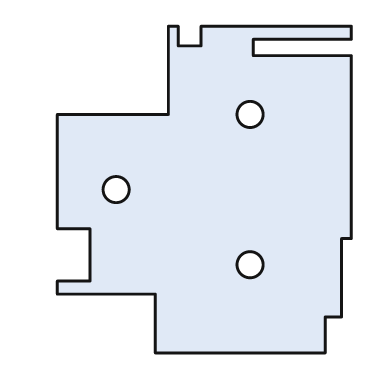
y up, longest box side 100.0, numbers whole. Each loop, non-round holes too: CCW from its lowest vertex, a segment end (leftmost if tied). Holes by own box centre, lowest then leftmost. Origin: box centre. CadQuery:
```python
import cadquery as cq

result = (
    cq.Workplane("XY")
    .moveTo(-15.0, -50.0)
    .lineTo(37.0, -50.0)
    .lineTo(37.0, -39.0)
    .lineTo(42.0, -39.0)
    .lineTo(42.0, -15.0)
    .lineTo(45.0, -15.0)
    .lineTo(45.0, 41.0)
    .lineTo(15.0, 41.0)
    .lineTo(15.0, 46.0)
    .lineTo(45.0, 46.0)
    .lineTo(45.0, 50.0)
    .lineTo(-1.0, 50.0)
    .lineTo(-1.0, 44.0)
    .lineTo(-8.0, 44.0)
    .lineTo(-8.0, 50.0)
    .lineTo(-11.0, 50.0)
    .lineTo(-11.0, 23.0)
    .lineTo(-45.0, 23.0)
    .lineTo(-45.0, -12.0)
    .lineTo(-35.0, -12.0)
    .lineTo(-35.0, -28.0)
    .lineTo(-45.0, -28.0)
    .lineTo(-45.0, -32.0)
    .lineTo(-15.0, -32.0)
    .close()
    .moveTo(14.0, -23.0)
    .circle(4.0)
    .moveTo(-27.0, 0.0)
    .circle(4.0)
    .moveTo(14.0, 23.0)
    .circle(4.0)
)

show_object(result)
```